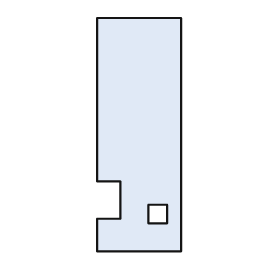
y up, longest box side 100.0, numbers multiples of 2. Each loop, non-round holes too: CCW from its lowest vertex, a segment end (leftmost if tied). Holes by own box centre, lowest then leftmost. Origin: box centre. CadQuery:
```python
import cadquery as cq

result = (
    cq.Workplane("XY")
    .moveTo(-18.0, -50.0)
    .lineTo(18.0, -50.0)
    .lineTo(18.0, 50.0)
    .lineTo(-18.0, 50.0)
    .lineTo(-18.0, -20.0)
    .lineTo(-8.0, -20.0)
    .lineTo(-8.0, -36.0)
    .lineTo(-18.0, -36.0)
    .close()
    .moveTo(4.0, -38.0)
    .lineTo(12.0, -38.0)
    .lineTo(12.0, -30.0)
    .lineTo(4.0, -30.0)
    .close()
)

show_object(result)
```